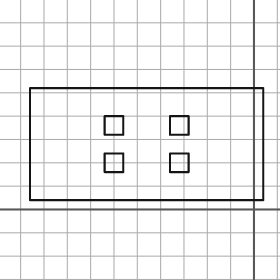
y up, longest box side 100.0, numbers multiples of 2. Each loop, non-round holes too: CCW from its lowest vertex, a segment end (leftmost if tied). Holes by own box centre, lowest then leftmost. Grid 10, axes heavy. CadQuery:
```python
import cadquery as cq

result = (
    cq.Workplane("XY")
    .moveTo(-96.0, 4.0)
    .lineTo(4.0, 4.0)
    .lineTo(4.0, 52.0)
    .lineTo(-96.0, 52.0)
    .close()
    .moveTo(-64.0, 16.0)
    .lineTo(-56.0, 16.0)
    .lineTo(-56.0, 24.0)
    .lineTo(-64.0, 24.0)
    .close()
    .moveTo(-36.0, 16.0)
    .lineTo(-28.0, 16.0)
    .lineTo(-28.0, 24.0)
    .lineTo(-36.0, 24.0)
    .close()
    .moveTo(-64.0, 32.0)
    .lineTo(-56.0, 32.0)
    .lineTo(-56.0, 40.0)
    .lineTo(-64.0, 40.0)
    .close()
    .moveTo(-36.0, 32.0)
    .lineTo(-28.0, 32.0)
    .lineTo(-28.0, 40.0)
    .lineTo(-36.0, 40.0)
    .close()
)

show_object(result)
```